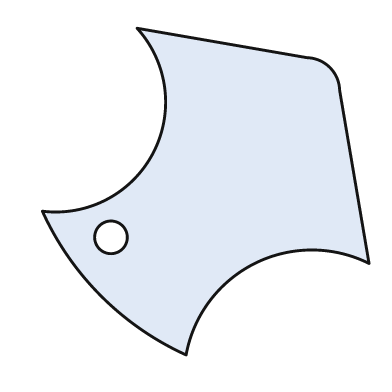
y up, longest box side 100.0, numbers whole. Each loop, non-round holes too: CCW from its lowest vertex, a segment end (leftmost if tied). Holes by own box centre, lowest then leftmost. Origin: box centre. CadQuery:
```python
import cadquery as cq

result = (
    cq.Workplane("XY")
    .moveTo(-6.0, -50.0)
    .threePointArc((15.0, -22.0), (50.0, -22.0))
    .lineTo(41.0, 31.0)
    .threePointArc((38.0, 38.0), (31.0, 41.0))
    .lineTo(-21.0, 50.0)
    .threePointArc((-16.0, 12.0), (-50.0, -6.0))
    .threePointArc((-32.0, -32.0), (-6.0, -50.0))
    .close()
    .moveTo(-29.0, -14.0)
    .circle(5.0)
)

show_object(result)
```